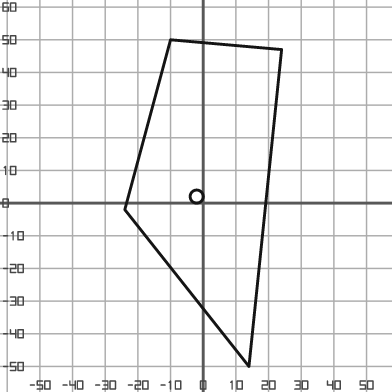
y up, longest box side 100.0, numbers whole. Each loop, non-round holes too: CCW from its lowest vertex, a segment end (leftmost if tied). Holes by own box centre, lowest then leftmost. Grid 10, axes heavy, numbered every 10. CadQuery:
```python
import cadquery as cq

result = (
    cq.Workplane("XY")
    .moveTo(14.0, -50.0)
    .lineTo(24.0, 47.0)
    .lineTo(-10.0, 50.0)
    .lineTo(-24.0, -2.0)
    .close()
    .moveTo(-2.0, 2.0)
    .circle(2.0)
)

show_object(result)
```